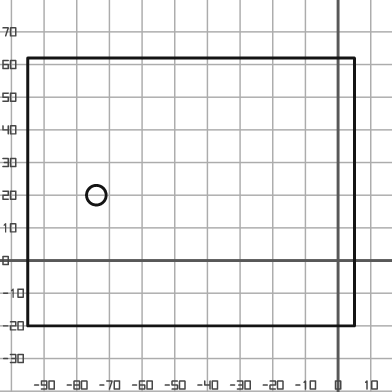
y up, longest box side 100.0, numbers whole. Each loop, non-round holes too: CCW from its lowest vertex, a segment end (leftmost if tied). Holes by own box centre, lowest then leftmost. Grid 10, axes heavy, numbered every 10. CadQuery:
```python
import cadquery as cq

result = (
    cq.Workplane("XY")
    .moveTo(-95.0, -20.0)
    .lineTo(5.0, -20.0)
    .lineTo(5.0, 62.0)
    .lineTo(-95.0, 62.0)
    .close()
    .moveTo(-74.0, 20.0)
    .circle(3.0)
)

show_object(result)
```